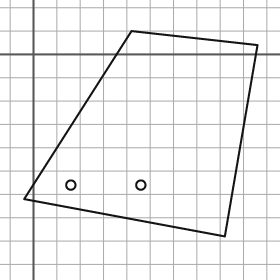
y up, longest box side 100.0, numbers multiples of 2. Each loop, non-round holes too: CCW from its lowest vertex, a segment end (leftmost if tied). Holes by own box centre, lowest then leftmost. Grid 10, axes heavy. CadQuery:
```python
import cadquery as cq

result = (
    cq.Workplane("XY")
    .moveTo(82.0, -78.0)
    .lineTo(96.0, 4.0)
    .lineTo(42.0, 10.0)
    .lineTo(-4.0, -62.0)
    .close()
    .moveTo(16.0, -56.0)
    .circle(2.0)
    .moveTo(46.0, -56.0)
    .circle(2.0)
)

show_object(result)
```